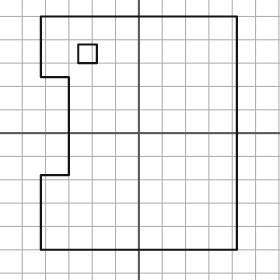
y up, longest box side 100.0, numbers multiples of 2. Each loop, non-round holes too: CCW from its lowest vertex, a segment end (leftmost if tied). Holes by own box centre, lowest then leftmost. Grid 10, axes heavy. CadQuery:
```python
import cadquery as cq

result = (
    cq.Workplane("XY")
    .moveTo(-42.0, -50.0)
    .lineTo(42.0, -50.0)
    .lineTo(42.0, 50.0)
    .lineTo(-42.0, 50.0)
    .lineTo(-42.0, 24.0)
    .lineTo(-30.0, 24.0)
    .lineTo(-30.0, -18.0)
    .lineTo(-42.0, -18.0)
    .close()
    .moveTo(-26.0, 30.0)
    .lineTo(-18.0, 30.0)
    .lineTo(-18.0, 38.0)
    .lineTo(-26.0, 38.0)
    .close()
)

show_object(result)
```